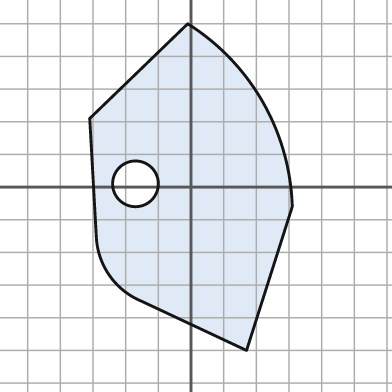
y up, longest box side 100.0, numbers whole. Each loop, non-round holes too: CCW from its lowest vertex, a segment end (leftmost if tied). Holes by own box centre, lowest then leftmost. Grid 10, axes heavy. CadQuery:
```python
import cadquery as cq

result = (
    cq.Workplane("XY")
    .moveTo(17.0, -50.0)
    .lineTo(31.0, -6.0)
    .threePointArc((22.0, 26.0), (-1.0, 50.0))
    .lineTo(-31.0, 21.0)
    .lineTo(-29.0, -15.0)
    .threePointArc((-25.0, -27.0), (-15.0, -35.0))
    .close()
    .moveTo(-17.0, 1.0)
    .circle(7.0)
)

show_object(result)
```